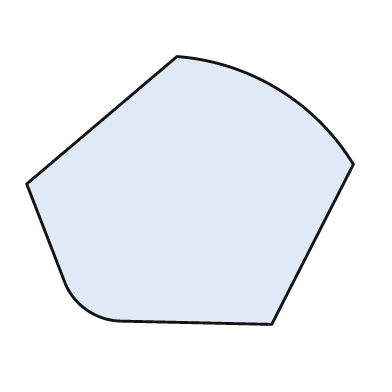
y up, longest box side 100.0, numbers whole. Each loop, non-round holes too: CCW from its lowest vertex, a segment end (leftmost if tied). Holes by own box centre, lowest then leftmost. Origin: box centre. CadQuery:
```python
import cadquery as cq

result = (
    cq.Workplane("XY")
    .moveTo(25.0, -41.0)
    .lineTo(50.0, 8.0)
    .threePointArc((27.0, 31.0), (-4.0, 41.0))
    .lineTo(-50.0, 2.0)
    .lineTo(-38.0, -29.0)
    .threePointArc((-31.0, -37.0), (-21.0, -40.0))
    .close()
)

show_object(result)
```